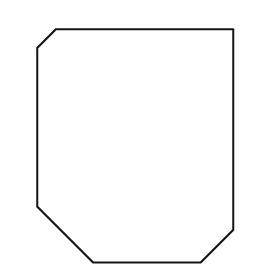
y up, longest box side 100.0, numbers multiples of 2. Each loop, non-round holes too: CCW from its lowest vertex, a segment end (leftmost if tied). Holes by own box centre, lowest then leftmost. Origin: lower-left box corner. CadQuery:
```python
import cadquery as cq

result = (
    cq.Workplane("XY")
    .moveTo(24.0, 0.0)
    .lineTo(70.0, 0.0)
    .lineTo(84.0, 14.0)
    .lineTo(84.0, 100.0)
    .lineTo(8.0, 100.0)
    .lineTo(0.0, 92.0)
    .lineTo(0.0, 24.0)
    .close()
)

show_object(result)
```